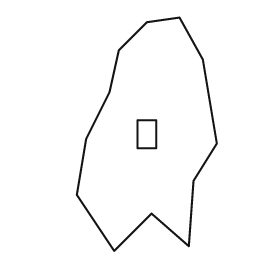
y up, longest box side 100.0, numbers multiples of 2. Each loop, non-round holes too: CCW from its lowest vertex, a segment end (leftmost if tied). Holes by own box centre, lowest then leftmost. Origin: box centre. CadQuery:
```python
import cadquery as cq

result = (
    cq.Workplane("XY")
    .moveTo(-14.0, -50.0)
    .lineTo(2.0, -34.0)
    .lineTo(18.0, -48.0)
    .lineTo(20.0, -20.0)
    .lineTo(30.0, -4.0)
    .lineTo(24.0, 32.0)
    .lineTo(14.0, 50.0)
    .lineTo(0.0, 48.0)
    .lineTo(-12.0, 36.0)
    .lineTo(-16.0, 18.0)
    .lineTo(-26.0, -2.0)
    .lineTo(-30.0, -26.0)
    .close()
    .moveTo(-4.0, -6.0)
    .lineTo(4.0, -6.0)
    .lineTo(4.0, 6.0)
    .lineTo(-4.0, 6.0)
    .close()
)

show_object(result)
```